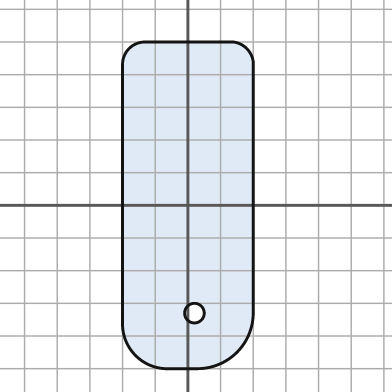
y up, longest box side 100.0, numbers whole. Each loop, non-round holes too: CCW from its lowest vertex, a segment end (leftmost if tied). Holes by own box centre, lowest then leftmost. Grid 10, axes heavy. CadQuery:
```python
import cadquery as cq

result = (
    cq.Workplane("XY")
    .moveTo(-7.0, -50.0)
    .lineTo(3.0, -50.0)
    .threePointArc((15.0, -45.0), (20.0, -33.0))
    .lineTo(20.0, 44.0)
    .threePointArc((18.0, 48.0), (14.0, 50.0))
    .lineTo(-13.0, 50.0)
    .threePointArc((-18.0, 48.0), (-20.0, 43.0))
    .lineTo(-20.0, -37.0)
    .threePointArc((-16.0, -46.0), (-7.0, -50.0))
    .close()
    .moveTo(2.0, -33.0)
    .circle(3.0)
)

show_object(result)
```